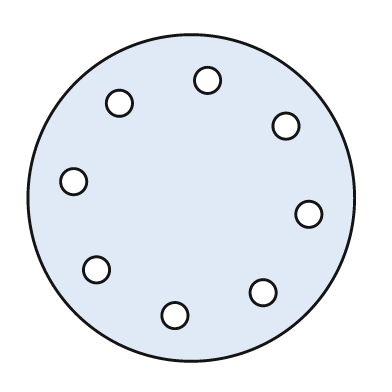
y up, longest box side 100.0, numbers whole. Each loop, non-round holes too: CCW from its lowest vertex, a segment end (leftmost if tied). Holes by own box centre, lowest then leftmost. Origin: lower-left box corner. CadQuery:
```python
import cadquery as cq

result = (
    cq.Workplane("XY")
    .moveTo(50.0, 50.0)
    .circle(50.0)
    .moveTo(45.0, 14.0)
    .circle(4.0)
    .moveTo(72.0, 21.0)
    .circle(4.0)
    .moveTo(21.0, 28.0)
    .circle(4.0)
    .moveTo(86.0, 45.0)
    .circle(4.0)
    .moveTo(14.0, 55.0)
    .circle(4.0)
    .moveTo(79.0, 72.0)
    .circle(4.0)
    .moveTo(28.0, 79.0)
    .circle(4.0)
    .moveTo(55.0, 86.0)
    .circle(4.0)
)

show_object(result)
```